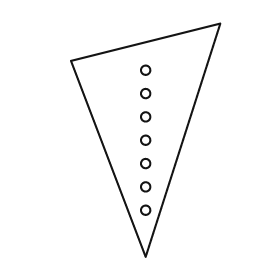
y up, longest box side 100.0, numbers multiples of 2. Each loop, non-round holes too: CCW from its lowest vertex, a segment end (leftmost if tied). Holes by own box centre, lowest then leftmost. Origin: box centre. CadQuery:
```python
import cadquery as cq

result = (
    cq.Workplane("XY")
    .moveTo(0.0, -50.0)
    .lineTo(32.0, 50.0)
    .lineTo(-32.0, 34.0)
    .close()
    .moveTo(0.0, -30.0)
    .circle(2.0)
    .moveTo(0.0, -20.0)
    .circle(2.0)
    .moveTo(0.0, -10.0)
    .circle(2.0)
    .moveTo(0.0, 0.0)
    .circle(2.0)
    .moveTo(0.0, 10.0)
    .circle(2.0)
    .moveTo(0.0, 20.0)
    .circle(2.0)
    .moveTo(0.0, 30.0)
    .circle(2.0)
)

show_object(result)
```